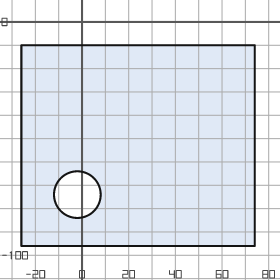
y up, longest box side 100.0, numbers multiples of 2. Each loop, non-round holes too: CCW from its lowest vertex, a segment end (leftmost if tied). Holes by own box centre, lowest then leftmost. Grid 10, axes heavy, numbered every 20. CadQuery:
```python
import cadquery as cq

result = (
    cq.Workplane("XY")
    .moveTo(-26.0, -96.0)
    .lineTo(74.0, -96.0)
    .lineTo(74.0, -10.0)
    .lineTo(-26.0, -10.0)
    .close()
    .moveTo(-2.0, -74.0)
    .circle(10.0)
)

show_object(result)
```